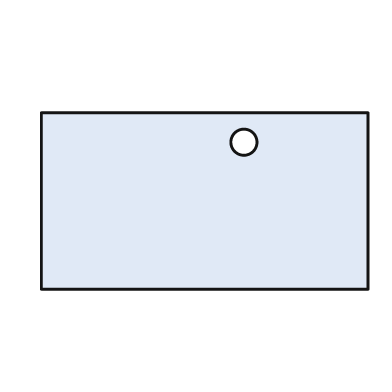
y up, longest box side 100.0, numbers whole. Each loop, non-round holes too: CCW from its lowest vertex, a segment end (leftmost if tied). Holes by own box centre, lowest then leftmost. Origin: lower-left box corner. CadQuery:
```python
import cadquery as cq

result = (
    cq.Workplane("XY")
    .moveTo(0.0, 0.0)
    .lineTo(100.0, 0.0)
    .lineTo(100.0, 54.0)
    .lineTo(0.0, 54.0)
    .close()
    .moveTo(62.0, 45.0)
    .circle(4.0)
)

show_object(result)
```